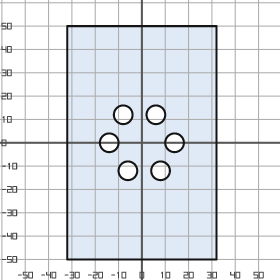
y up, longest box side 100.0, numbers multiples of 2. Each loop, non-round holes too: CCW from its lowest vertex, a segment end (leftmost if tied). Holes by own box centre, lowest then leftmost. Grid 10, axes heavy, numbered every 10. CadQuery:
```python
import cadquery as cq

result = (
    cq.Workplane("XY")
    .moveTo(-32.0, -50.0)
    .lineTo(32.0, -50.0)
    .lineTo(32.0, 50.0)
    .lineTo(-32.0, 50.0)
    .close()
    .moveTo(-6.0, -12.0)
    .circle(4.0)
    .moveTo(8.0, -12.0)
    .circle(4.0)
    .moveTo(-14.0, 0.0)
    .circle(4.0)
    .moveTo(14.0, 0.0)
    .circle(4.0)
    .moveTo(-8.0, 12.0)
    .circle(4.0)
    .moveTo(6.0, 12.0)
    .circle(4.0)
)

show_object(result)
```